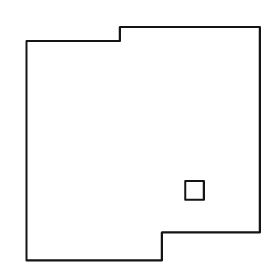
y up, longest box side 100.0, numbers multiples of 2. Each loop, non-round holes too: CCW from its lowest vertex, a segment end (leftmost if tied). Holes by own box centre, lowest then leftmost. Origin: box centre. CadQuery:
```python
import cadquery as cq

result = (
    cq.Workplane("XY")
    .moveTo(-50.0, -50.0)
    .lineTo(8.0, -50.0)
    .lineTo(8.0, -38.0)
    .lineTo(50.0, -38.0)
    .lineTo(50.0, 50.0)
    .lineTo(-10.0, 50.0)
    .lineTo(-10.0, 44.0)
    .lineTo(-50.0, 44.0)
    .close()
    .moveTo(18.0, -24.0)
    .lineTo(26.0, -24.0)
    .lineTo(26.0, -16.0)
    .lineTo(18.0, -16.0)
    .close()
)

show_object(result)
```